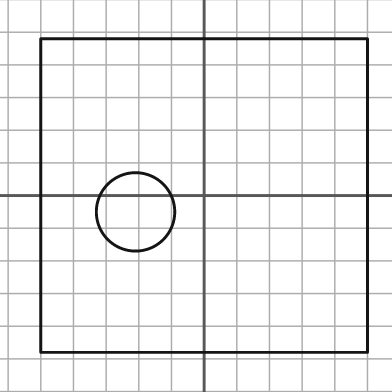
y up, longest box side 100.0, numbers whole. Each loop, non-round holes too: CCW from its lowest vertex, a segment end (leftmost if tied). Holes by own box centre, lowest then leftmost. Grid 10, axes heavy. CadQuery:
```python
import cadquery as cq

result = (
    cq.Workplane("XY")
    .moveTo(-50.0, -48.0)
    .lineTo(50.0, -48.0)
    .lineTo(50.0, 48.0)
    .lineTo(-50.0, 48.0)
    .close()
    .moveTo(-21.0, -5.0)
    .circle(12.0)
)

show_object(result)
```